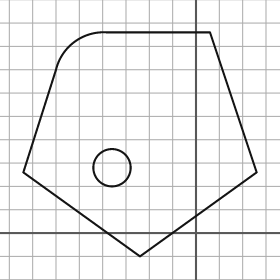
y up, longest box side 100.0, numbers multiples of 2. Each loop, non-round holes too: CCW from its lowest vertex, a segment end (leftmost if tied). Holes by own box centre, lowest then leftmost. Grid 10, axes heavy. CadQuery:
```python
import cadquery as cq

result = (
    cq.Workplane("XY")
    .moveTo(-24.0, -10.0)
    .lineTo(26.0, 26.0)
    .lineTo(6.0, 86.0)
    .lineTo(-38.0, 86.0)
    .threePointArc((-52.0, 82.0), (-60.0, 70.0))
    .lineTo(-74.0, 26.0)
    .close()
    .moveTo(-36.0, 28.0)
    .circle(8.0)
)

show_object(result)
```